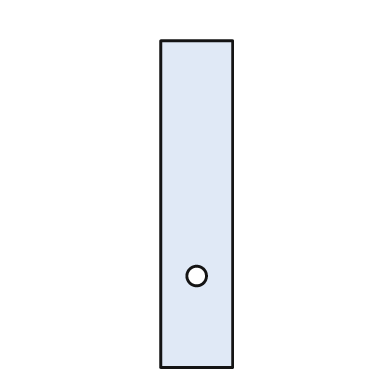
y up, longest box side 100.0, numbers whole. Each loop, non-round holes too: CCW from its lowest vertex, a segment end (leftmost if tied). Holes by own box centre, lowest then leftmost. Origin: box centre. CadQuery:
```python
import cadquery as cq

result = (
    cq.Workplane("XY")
    .moveTo(-11.0, -50.0)
    .lineTo(11.0, -50.0)
    .lineTo(11.0, 50.0)
    .lineTo(-11.0, 50.0)
    .close()
    .moveTo(0.0, -22.0)
    .circle(3.0)
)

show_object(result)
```